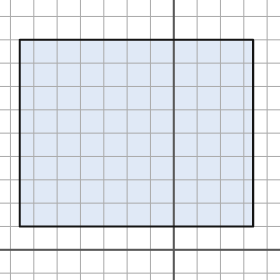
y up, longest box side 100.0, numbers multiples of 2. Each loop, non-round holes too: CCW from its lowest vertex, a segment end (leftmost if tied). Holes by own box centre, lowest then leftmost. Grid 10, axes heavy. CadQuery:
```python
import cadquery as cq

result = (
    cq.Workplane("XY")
    .moveTo(-66.0, 10.0)
    .lineTo(34.0, 10.0)
    .lineTo(34.0, 90.0)
    .lineTo(-66.0, 90.0)
    .close()
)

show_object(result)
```